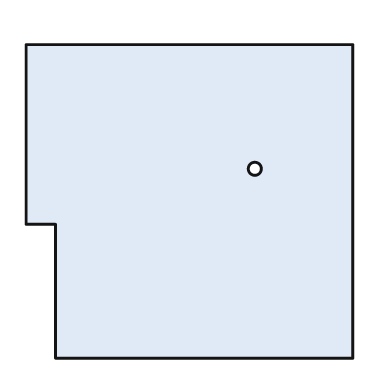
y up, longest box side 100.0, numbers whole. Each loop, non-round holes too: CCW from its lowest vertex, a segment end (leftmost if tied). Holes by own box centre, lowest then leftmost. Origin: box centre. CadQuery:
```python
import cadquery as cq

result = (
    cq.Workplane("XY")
    .moveTo(-41.0, -48.0)
    .lineTo(50.0, -48.0)
    .lineTo(50.0, 48.0)
    .lineTo(-50.0, 48.0)
    .lineTo(-50.0, -7.0)
    .lineTo(-41.0, -7.0)
    .close()
    .moveTo(20.0, 10.0)
    .circle(2.0)
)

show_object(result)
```